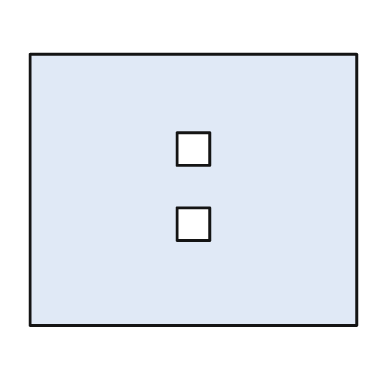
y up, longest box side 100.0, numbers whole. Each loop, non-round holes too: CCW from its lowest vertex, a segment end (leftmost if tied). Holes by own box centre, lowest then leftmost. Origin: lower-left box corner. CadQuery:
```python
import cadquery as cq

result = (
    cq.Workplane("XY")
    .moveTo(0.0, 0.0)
    .lineTo(100.0, 0.0)
    .lineTo(100.0, 83.0)
    .lineTo(0.0, 83.0)
    .close()
    .moveTo(45.0, 26.0)
    .lineTo(55.0, 26.0)
    .lineTo(55.0, 36.0)
    .lineTo(45.0, 36.0)
    .close()
    .moveTo(45.0, 49.0)
    .lineTo(55.0, 49.0)
    .lineTo(55.0, 59.0)
    .lineTo(45.0, 59.0)
    .close()
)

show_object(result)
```